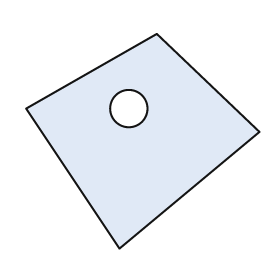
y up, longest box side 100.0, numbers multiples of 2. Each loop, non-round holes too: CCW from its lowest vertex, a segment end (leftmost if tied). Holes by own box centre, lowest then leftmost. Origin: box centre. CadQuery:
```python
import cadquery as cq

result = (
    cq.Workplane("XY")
    .moveTo(-10.0, -46.0)
    .lineTo(50.0, 4.0)
    .lineTo(6.0, 46.0)
    .lineTo(-50.0, 14.0)
    .close()
    .moveTo(-6.0, 14.0)
    .circle(8.0)
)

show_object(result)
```